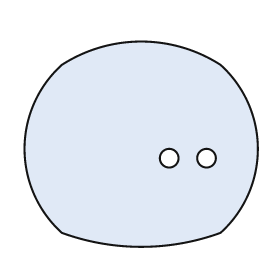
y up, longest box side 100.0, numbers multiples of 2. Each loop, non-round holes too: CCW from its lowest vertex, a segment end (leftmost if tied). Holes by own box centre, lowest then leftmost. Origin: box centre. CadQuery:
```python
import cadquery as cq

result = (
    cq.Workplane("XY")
    .moveTo(-34.0, -38.0)
    .threePointArc((0.0, -44.0), (34.0, -38.0))
    .threePointArc((50.0, -2.0), (34.0, 34.0))
    .threePointArc((0.0, 44.0), (-34.0, 34.0))
    .threePointArc((-50.0, -2.0), (-34.0, -38.0))
    .close()
    .moveTo(12.0, -6.0)
    .circle(4.0)
    .moveTo(28.0, -6.0)
    .circle(4.0)
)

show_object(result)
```